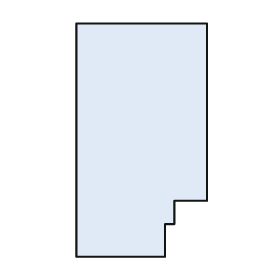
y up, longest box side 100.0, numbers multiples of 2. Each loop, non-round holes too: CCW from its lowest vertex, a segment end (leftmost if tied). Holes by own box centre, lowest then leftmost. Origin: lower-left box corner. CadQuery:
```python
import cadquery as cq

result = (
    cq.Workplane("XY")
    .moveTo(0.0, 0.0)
    .lineTo(38.0, 0.0)
    .lineTo(38.0, 14.0)
    .lineTo(42.0, 14.0)
    .lineTo(42.0, 24.0)
    .lineTo(56.0, 24.0)
    .lineTo(56.0, 100.0)
    .lineTo(0.0, 100.0)
    .close()
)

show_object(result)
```